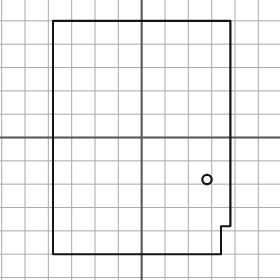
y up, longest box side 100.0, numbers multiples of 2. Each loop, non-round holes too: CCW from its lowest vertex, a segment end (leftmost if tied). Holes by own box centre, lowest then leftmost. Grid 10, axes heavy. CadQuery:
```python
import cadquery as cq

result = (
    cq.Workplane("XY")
    .moveTo(-38.0, -50.0)
    .lineTo(34.0, -50.0)
    .lineTo(34.0, -38.0)
    .lineTo(38.0, -38.0)
    .lineTo(38.0, 50.0)
    .lineTo(-38.0, 50.0)
    .close()
    .moveTo(28.0, -18.0)
    .circle(2.0)
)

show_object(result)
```